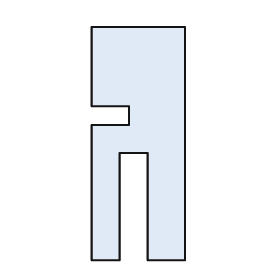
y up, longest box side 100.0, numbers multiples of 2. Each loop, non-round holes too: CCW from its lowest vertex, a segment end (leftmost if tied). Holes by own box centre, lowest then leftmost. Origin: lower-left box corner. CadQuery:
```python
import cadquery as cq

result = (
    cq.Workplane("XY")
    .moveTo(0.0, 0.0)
    .lineTo(12.0, 0.0)
    .lineTo(12.0, 46.0)
    .lineTo(24.0, 46.0)
    .lineTo(24.0, 0.0)
    .lineTo(40.0, 0.0)
    .lineTo(40.0, 100.0)
    .lineTo(0.0, 100.0)
    .lineTo(0.0, 66.0)
    .lineTo(16.0, 66.0)
    .lineTo(16.0, 58.0)
    .lineTo(0.0, 58.0)
    .close()
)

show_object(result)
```